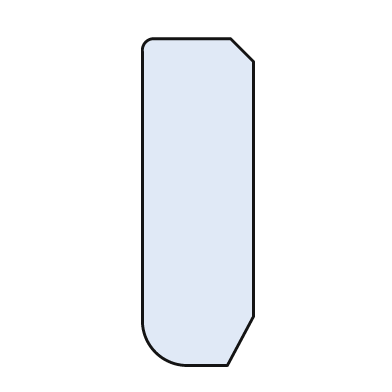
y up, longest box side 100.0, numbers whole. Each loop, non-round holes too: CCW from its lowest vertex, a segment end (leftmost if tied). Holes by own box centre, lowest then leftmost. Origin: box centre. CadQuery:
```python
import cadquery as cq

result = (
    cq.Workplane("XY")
    .moveTo(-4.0, -50.0)
    .lineTo(9.0, -50.0)
    .lineTo(17.0, -35.0)
    .lineTo(17.0, 43.0)
    .lineTo(10.0, 50.0)
    .lineTo(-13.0, 50.0)
    .threePointArc((-16.0, 49.0), (-17.0, 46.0))
    .lineTo(-17.0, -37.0)
    .threePointArc((-13.0, -46.0), (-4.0, -50.0))
    .close()
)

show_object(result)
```